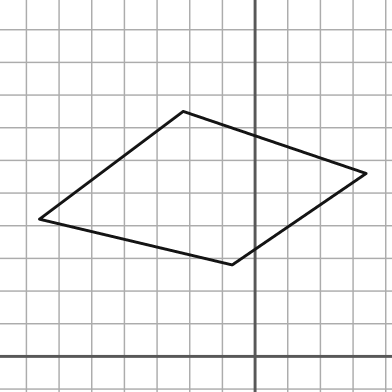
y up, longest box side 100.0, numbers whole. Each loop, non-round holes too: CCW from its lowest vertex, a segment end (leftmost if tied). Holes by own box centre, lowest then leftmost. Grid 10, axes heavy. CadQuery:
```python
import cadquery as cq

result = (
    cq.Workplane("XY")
    .moveTo(-7.0, 28.0)
    .lineTo(34.0, 56.0)
    .lineTo(-22.0, 75.0)
    .lineTo(-66.0, 42.0)
    .close()
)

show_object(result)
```